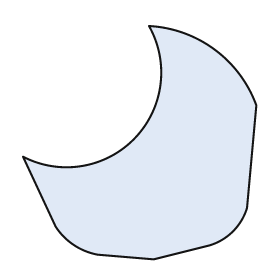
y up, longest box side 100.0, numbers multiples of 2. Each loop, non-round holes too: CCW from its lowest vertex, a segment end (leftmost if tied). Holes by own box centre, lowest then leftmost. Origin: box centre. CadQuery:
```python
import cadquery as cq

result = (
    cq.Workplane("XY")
    .moveTo(6.0, -50.0)
    .lineTo(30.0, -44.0)
    .threePointArc((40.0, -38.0), (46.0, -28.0))
    .lineTo(50.0, 16.0)
    .threePointArc((32.0, 40.0), (4.0, 50.0))
    .threePointArc((-2.0, 2.0), (-50.0, -6.0))
    .lineTo(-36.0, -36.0)
    .threePointArc((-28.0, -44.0), (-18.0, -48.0))
    .close()
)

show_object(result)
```